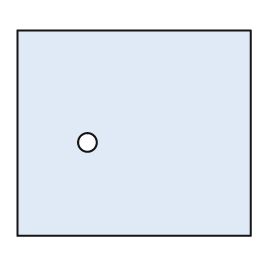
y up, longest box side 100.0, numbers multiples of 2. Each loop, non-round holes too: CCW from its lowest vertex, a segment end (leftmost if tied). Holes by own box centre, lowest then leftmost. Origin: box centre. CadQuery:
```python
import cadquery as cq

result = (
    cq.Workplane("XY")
    .moveTo(-50.0, -44.0)
    .lineTo(50.0, -44.0)
    .lineTo(50.0, 44.0)
    .lineTo(-50.0, 44.0)
    .close()
    .moveTo(-20.0, -4.0)
    .circle(4.0)
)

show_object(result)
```